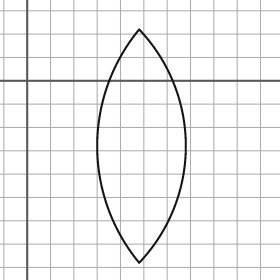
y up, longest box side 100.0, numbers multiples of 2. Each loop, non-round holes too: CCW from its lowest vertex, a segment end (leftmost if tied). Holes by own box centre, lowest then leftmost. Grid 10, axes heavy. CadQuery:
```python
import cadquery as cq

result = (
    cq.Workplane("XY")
    .moveTo(48.0, -78.0)
    .threePointArc((68.0, -28.0), (48.0, 22.0))
    .threePointArc((30.0, -28.0), (48.0, -78.0))
    .close()
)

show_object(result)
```